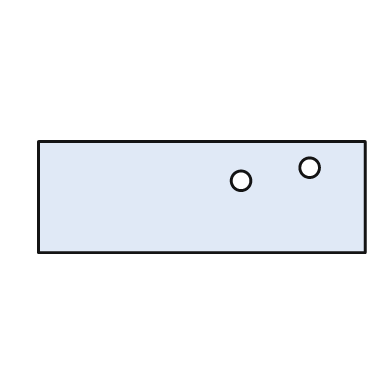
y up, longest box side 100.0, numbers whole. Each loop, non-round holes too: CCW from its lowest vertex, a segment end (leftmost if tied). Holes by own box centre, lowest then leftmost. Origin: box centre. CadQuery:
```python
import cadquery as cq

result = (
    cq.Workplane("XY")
    .moveTo(-50.0, -17.0)
    .lineTo(50.0, -17.0)
    .lineTo(50.0, 17.0)
    .lineTo(-50.0, 17.0)
    .close()
    .moveTo(12.0, 5.0)
    .circle(3.0)
    .moveTo(33.0, 9.0)
    .circle(3.0)
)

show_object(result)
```